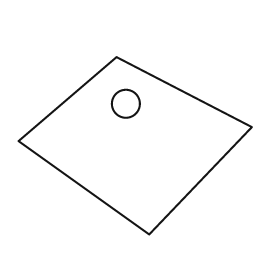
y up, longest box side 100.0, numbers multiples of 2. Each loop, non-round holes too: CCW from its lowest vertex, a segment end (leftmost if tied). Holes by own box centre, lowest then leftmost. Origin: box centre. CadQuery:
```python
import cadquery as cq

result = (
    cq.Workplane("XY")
    .moveTo(6.0, -38.0)
    .lineTo(50.0, 8.0)
    .lineTo(-8.0, 38.0)
    .lineTo(-50.0, 2.0)
    .close()
    .moveTo(-4.0, 18.0)
    .circle(6.0)
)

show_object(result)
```